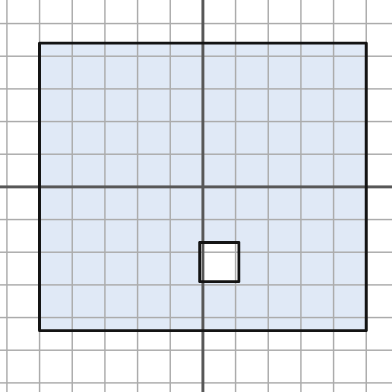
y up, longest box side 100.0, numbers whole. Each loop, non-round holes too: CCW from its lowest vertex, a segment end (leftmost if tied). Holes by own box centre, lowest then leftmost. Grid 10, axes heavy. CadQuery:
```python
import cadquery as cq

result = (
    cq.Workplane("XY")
    .moveTo(-50.0, -44.0)
    .lineTo(50.0, -44.0)
    .lineTo(50.0, 44.0)
    .lineTo(-50.0, 44.0)
    .close()
    .moveTo(-1.0, -29.0)
    .lineTo(11.0, -29.0)
    .lineTo(11.0, -17.0)
    .lineTo(-1.0, -17.0)
    .close()
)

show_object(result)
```